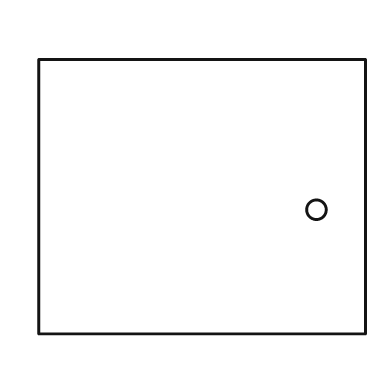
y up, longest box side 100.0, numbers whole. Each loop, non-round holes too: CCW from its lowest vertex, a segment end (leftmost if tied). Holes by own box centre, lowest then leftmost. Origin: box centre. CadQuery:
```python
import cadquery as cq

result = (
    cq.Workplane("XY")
    .moveTo(-50.0, -42.0)
    .lineTo(50.0, -42.0)
    .lineTo(50.0, 42.0)
    .lineTo(-50.0, 42.0)
    .close()
    .moveTo(35.0, -4.0)
    .circle(3.0)
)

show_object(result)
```